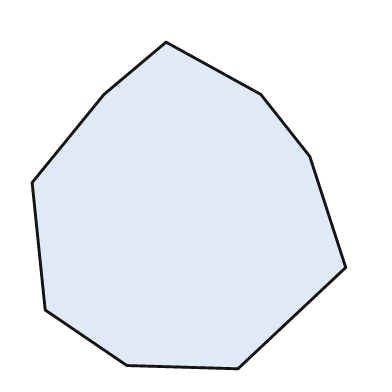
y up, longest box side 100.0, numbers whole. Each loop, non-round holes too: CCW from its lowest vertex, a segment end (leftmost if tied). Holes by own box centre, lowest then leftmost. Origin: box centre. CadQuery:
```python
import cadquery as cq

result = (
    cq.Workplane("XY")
    .moveTo(15.0, -50.0)
    .lineTo(48.0, -19.0)
    .lineTo(37.0, 15.0)
    .lineTo(22.0, 34.0)
    .lineTo(-7.0, 50.0)
    .lineTo(-26.0, 34.0)
    .lineTo(-48.0, 7.0)
    .lineTo(-44.0, -32.0)
    .lineTo(-19.0, -49.0)
    .close()
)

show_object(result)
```